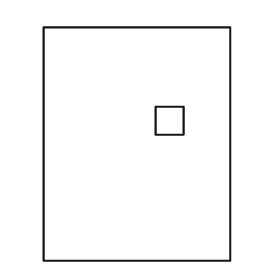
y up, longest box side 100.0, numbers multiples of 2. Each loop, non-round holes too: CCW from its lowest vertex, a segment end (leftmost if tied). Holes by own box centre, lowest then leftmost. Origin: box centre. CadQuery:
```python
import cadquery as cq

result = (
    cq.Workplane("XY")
    .moveTo(-40.0, -50.0)
    .lineTo(40.0, -50.0)
    .lineTo(40.0, 50.0)
    .lineTo(-40.0, 50.0)
    .close()
    .moveTo(8.0, 4.0)
    .lineTo(20.0, 4.0)
    .lineTo(20.0, 16.0)
    .lineTo(8.0, 16.0)
    .close()
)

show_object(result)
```